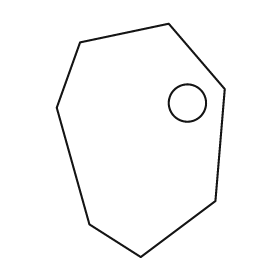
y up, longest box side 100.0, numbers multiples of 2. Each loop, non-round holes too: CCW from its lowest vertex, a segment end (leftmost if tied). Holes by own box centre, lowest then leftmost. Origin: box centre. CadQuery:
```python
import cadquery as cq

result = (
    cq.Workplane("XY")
    .moveTo(0.0, -50.0)
    .lineTo(32.0, -26.0)
    .lineTo(36.0, 22.0)
    .lineTo(12.0, 50.0)
    .lineTo(-26.0, 42.0)
    .lineTo(-36.0, 14.0)
    .lineTo(-22.0, -36.0)
    .close()
    .moveTo(20.0, 16.0)
    .circle(8.0)
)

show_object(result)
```